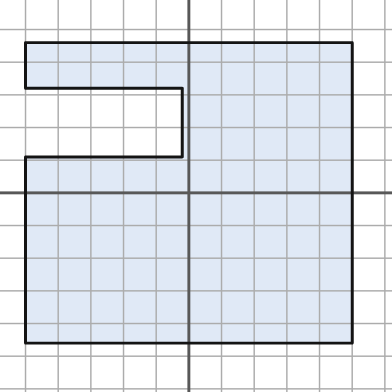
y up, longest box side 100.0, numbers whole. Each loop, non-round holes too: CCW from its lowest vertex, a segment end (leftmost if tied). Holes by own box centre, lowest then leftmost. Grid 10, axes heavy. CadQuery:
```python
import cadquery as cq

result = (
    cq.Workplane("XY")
    .moveTo(-50.0, -46.0)
    .lineTo(50.0, -46.0)
    .lineTo(50.0, 46.0)
    .lineTo(-50.0, 46.0)
    .lineTo(-50.0, 32.0)
    .lineTo(-2.0, 32.0)
    .lineTo(-2.0, 11.0)
    .lineTo(-50.0, 11.0)
    .close()
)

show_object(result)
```